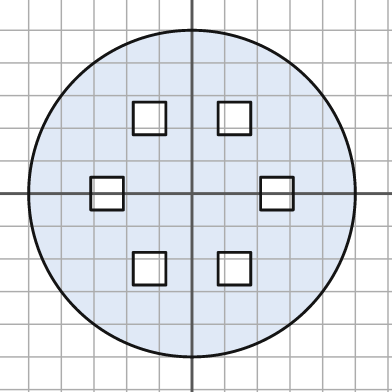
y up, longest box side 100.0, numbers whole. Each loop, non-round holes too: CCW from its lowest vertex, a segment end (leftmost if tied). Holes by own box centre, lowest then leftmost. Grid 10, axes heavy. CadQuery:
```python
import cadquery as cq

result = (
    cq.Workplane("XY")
    .moveTo(0.0, 0.0)
    .circle(50.0)
    .moveTo(-18.0, -28.0)
    .lineTo(-8.0, -28.0)
    .lineTo(-8.0, -18.0)
    .lineTo(-18.0, -18.0)
    .close()
    .moveTo(8.0, -28.0)
    .lineTo(18.0, -28.0)
    .lineTo(18.0, -18.0)
    .lineTo(8.0, -18.0)
    .close()
    .moveTo(-31.0, -5.0)
    .lineTo(-21.0, -5.0)
    .lineTo(-21.0, 5.0)
    .lineTo(-31.0, 5.0)
    .close()
    .moveTo(21.0, -5.0)
    .lineTo(31.0, -5.0)
    .lineTo(31.0, 5.0)
    .lineTo(21.0, 5.0)
    .close()
    .moveTo(-18.0, 18.0)
    .lineTo(-8.0, 18.0)
    .lineTo(-8.0, 28.0)
    .lineTo(-18.0, 28.0)
    .close()
    .moveTo(8.0, 18.0)
    .lineTo(18.0, 18.0)
    .lineTo(18.0, 28.0)
    .lineTo(8.0, 28.0)
    .close()
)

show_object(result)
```